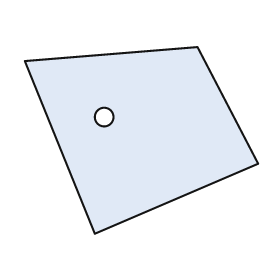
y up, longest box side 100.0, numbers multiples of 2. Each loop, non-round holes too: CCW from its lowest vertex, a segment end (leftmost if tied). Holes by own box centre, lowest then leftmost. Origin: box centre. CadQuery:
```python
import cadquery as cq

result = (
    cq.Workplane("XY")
    .moveTo(-20.0, -40.0)
    .lineTo(50.0, -10.0)
    .lineTo(24.0, 40.0)
    .lineTo(-50.0, 34.0)
    .close()
    .moveTo(-16.0, 10.0)
    .circle(4.0)
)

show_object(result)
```